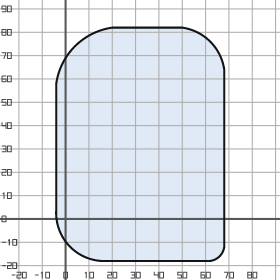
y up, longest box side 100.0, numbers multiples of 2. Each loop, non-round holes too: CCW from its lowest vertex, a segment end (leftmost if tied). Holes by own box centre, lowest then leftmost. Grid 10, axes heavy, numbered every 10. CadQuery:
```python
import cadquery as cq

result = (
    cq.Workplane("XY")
    .moveTo(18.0, -18.0)
    .lineTo(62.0, -18.0)
    .threePointArc((66.0, -16.0), (68.0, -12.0))
    .lineTo(68.0, 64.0)
    .threePointArc((62.0, 76.0), (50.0, 82.0))
    .lineTo(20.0, 82.0)
    .threePointArc((4.0, 74.0), (-4.0, 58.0))
    .lineTo(-4.0, 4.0)
    .threePointArc((2.0, -12.0), (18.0, -18.0))
    .close()
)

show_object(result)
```